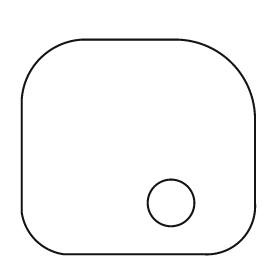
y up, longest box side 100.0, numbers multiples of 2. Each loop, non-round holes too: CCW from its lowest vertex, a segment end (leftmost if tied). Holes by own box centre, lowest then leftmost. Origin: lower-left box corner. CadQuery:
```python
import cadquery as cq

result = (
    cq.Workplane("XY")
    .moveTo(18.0, 0.0)
    .lineTo(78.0, 0.0)
    .threePointArc((94.0, 6.0), (100.0, 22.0))
    .lineTo(100.0, 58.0)
    .threePointArc((90.0, 82.0), (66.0, 92.0))
    .lineTo(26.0, 92.0)
    .threePointArc((8.0, 84.0), (0.0, 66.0))
    .lineTo(0.0, 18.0)
    .threePointArc((6.0, 6.0), (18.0, 0.0))
    .close()
    .moveTo(64.0, 22.0)
    .circle(10.0)
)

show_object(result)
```